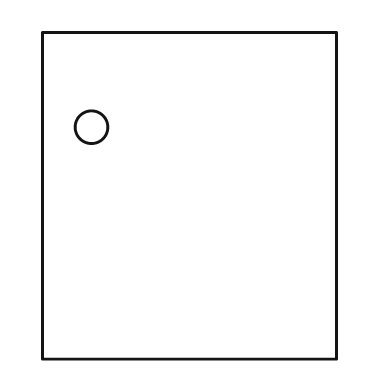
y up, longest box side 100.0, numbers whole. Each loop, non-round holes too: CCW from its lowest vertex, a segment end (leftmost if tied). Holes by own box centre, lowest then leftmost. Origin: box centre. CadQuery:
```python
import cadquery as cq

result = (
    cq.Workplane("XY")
    .moveTo(-45.0, -50.0)
    .lineTo(45.0, -50.0)
    .lineTo(45.0, 50.0)
    .lineTo(-45.0, 50.0)
    .close()
    .moveTo(-30.0, 21.0)
    .circle(5.0)
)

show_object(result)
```